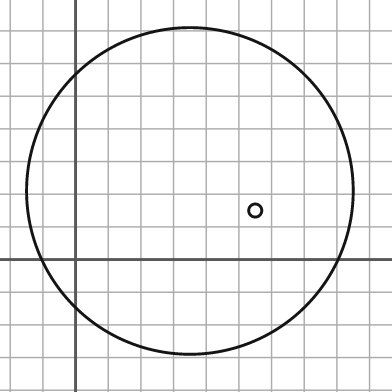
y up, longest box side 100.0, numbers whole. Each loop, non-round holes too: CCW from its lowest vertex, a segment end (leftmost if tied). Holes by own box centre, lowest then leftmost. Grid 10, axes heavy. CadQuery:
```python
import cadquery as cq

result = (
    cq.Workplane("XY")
    .moveTo(35.0, 21.0)
    .circle(50.0)
    .moveTo(55.0, 15.0)
    .circle(2.0)
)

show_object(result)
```